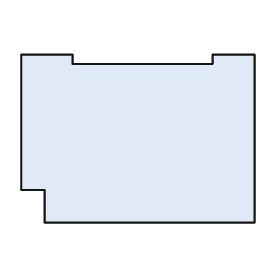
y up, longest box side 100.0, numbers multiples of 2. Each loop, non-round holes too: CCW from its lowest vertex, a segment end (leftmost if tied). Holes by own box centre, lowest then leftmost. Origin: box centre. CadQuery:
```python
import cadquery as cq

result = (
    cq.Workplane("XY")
    .moveTo(-40.0, -36.0)
    .lineTo(50.0, -36.0)
    .lineTo(50.0, 36.0)
    .lineTo(32.0, 36.0)
    .lineTo(32.0, 32.0)
    .lineTo(-28.0, 32.0)
    .lineTo(-28.0, 36.0)
    .lineTo(-50.0, 36.0)
    .lineTo(-50.0, -22.0)
    .lineTo(-40.0, -22.0)
    .close()
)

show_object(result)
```